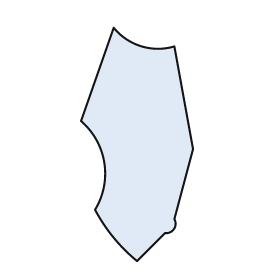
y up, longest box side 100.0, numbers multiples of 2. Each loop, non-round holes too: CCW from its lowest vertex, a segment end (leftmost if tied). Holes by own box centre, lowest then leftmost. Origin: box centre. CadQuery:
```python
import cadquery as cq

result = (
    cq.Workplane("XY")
    .moveTo(0.0, -50.0)
    .lineTo(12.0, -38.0)
    .threePointArc((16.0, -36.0), (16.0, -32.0))
    .lineTo(24.0, -2.0)
    .lineTo(16.0, 42.0)
    .threePointArc((2.0, 42.0), (-10.0, 50.0))
    .lineTo(-24.0, 10.0)
    .threePointArc((-14.0, -8.0), (-18.0, -28.0))
    .threePointArc((-10.0, -40.0), (0.0, -50.0))
    .close()
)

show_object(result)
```